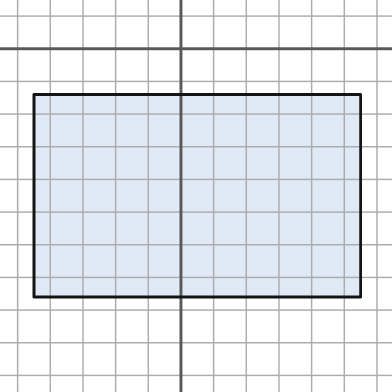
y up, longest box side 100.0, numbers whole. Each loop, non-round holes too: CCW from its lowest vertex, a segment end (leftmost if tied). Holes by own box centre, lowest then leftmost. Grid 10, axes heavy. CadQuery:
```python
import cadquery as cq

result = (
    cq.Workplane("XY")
    .moveTo(-45.0, -76.0)
    .lineTo(55.0, -76.0)
    .lineTo(55.0, -14.0)
    .lineTo(-45.0, -14.0)
    .close()
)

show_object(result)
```